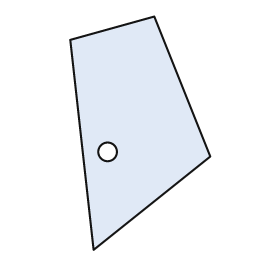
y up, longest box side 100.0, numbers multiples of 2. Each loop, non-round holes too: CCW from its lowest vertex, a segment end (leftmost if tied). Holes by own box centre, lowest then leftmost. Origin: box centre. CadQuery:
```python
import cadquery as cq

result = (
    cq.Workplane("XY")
    .moveTo(-20.0, -50.0)
    .lineTo(30.0, -10.0)
    .lineTo(6.0, 50.0)
    .lineTo(-30.0, 40.0)
    .close()
    .moveTo(-14.0, -8.0)
    .circle(4.0)
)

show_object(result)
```